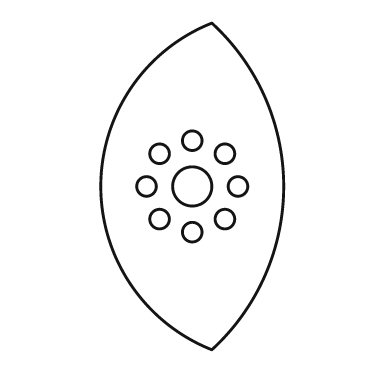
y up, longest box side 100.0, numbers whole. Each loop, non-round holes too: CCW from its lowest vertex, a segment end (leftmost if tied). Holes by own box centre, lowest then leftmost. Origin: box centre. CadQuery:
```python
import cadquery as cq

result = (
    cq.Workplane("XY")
    .moveTo(6.0, -50.0)
    .threePointArc((28.0, 0.0), (6.0, 50.0))
    .threePointArc((-28.0, 0.0), (6.0, -50.0))
    .close()
    .moveTo(0.0, -14.0)
    .circle(3.0)
    .moveTo(-10.0, -10.0)
    .circle(3.0)
    .moveTo(10.0, -10.0)
    .circle(3.0)
    .moveTo(-14.0, 0.0)
    .circle(3.0)
    .moveTo(0.0, 0.0)
    .circle(6.0)
    .moveTo(14.0, 0.0)
    .circle(3.0)
    .moveTo(-10.0, 10.0)
    .circle(3.0)
    .moveTo(10.0, 10.0)
    .circle(3.0)
    .moveTo(0.0, 14.0)
    .circle(3.0)
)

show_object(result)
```